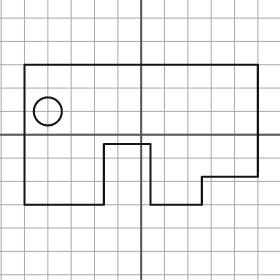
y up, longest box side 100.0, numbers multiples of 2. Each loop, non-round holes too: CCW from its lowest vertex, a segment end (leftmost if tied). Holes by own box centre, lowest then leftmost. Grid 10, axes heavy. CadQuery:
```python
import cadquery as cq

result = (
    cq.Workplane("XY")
    .moveTo(-50.0, -30.0)
    .lineTo(-16.0, -30.0)
    .lineTo(-16.0, -4.0)
    .lineTo(4.0, -4.0)
    .lineTo(4.0, -30.0)
    .lineTo(26.0, -30.0)
    .lineTo(26.0, -18.0)
    .lineTo(50.0, -18.0)
    .lineTo(50.0, 30.0)
    .lineTo(-50.0, 30.0)
    .close()
    .moveTo(-40.0, 10.0)
    .circle(6.0)
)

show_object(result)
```